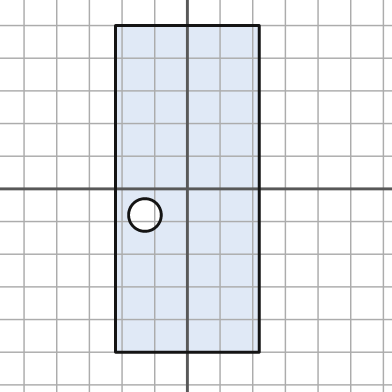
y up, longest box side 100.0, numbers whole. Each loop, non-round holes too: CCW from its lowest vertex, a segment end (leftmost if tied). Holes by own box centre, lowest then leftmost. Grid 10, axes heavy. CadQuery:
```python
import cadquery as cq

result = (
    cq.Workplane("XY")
    .moveTo(-22.0, -50.0)
    .lineTo(22.0, -50.0)
    .lineTo(22.0, 50.0)
    .lineTo(-22.0, 50.0)
    .close()
    .moveTo(-13.0, -8.0)
    .circle(5.0)
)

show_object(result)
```